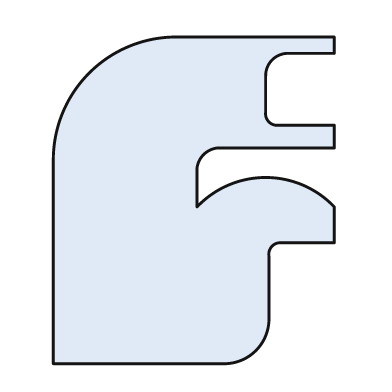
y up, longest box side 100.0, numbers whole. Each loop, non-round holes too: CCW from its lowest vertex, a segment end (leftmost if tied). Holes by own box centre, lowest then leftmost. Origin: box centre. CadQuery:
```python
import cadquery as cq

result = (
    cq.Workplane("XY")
    .moveTo(-43.0, -50.0)
    .lineTo(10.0, -50.0)
    .threePointArc((19.0, -46.0), (23.0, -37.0))
    .lineTo(23.0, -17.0)
    .threePointArc((24.0, -14.0), (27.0, -13.0))
    .lineTo(43.0, -13.0)
    .lineTo(43.0, -2.0)
    .threePointArc((22.0, 7.0), (1.0, -2.0))
    .lineTo(1.0, 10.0)
    .threePointArc((3.0, 14.0), (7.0, 16.0))
    .lineTo(43.0, 16.0)
    .lineTo(43.0, 23.0)
    .lineTo(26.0, 23.0)
    .threePointArc((23.0, 24.0), (22.0, 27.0))
    .lineTo(22.0, 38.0)
    .threePointArc((24.0, 43.0), (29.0, 45.0))
    .lineTo(43.0, 45.0)
    .lineTo(43.0, 50.0)
    .lineTo(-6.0, 50.0)
    .threePointArc((-32.0, 39.0), (-43.0, 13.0))
    .close()
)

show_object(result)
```